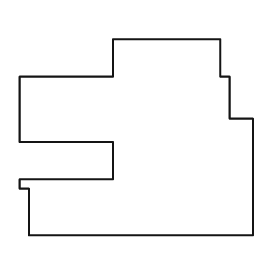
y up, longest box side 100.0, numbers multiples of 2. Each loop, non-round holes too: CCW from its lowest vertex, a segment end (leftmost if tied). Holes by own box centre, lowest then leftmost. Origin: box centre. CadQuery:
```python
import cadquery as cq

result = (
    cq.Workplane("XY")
    .moveTo(-46.0, -42.0)
    .lineTo(50.0, -42.0)
    .lineTo(50.0, 8.0)
    .lineTo(40.0, 8.0)
    .lineTo(40.0, 26.0)
    .lineTo(36.0, 26.0)
    .lineTo(36.0, 42.0)
    .lineTo(-10.0, 42.0)
    .lineTo(-10.0, 26.0)
    .lineTo(-50.0, 26.0)
    .lineTo(-50.0, -2.0)
    .lineTo(-10.0, -2.0)
    .lineTo(-10.0, -18.0)
    .lineTo(-50.0, -18.0)
    .lineTo(-50.0, -22.0)
    .lineTo(-46.0, -22.0)
    .close()
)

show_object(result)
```